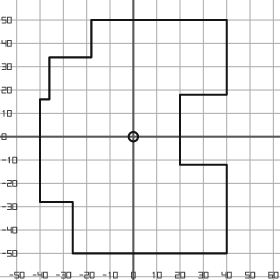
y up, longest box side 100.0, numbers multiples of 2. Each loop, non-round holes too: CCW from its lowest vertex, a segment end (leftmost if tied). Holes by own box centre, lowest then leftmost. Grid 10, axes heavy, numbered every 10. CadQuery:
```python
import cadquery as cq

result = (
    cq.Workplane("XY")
    .moveTo(-26.0, -50.0)
    .lineTo(40.0, -50.0)
    .lineTo(40.0, -12.0)
    .lineTo(20.0, -12.0)
    .lineTo(20.0, 18.0)
    .lineTo(40.0, 18.0)
    .lineTo(40.0, 50.0)
    .lineTo(-18.0, 50.0)
    .lineTo(-18.0, 34.0)
    .lineTo(-36.0, 34.0)
    .lineTo(-36.0, 16.0)
    .lineTo(-40.0, 16.0)
    .lineTo(-40.0, -28.0)
    .lineTo(-26.0, -28.0)
    .close()
    .moveTo(0.0, 0.0)
    .circle(2.0)
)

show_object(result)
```